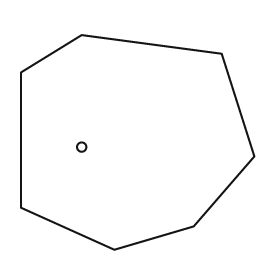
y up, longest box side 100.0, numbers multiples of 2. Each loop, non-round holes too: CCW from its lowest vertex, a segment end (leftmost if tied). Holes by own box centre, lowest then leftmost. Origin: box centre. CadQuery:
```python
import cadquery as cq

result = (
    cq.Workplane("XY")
    .moveTo(-10.0, -46.0)
    .lineTo(24.0, -36.0)
    .lineTo(50.0, -6.0)
    .lineTo(36.0, 38.0)
    .lineTo(-24.0, 46.0)
    .lineTo(-50.0, 30.0)
    .lineTo(-50.0, -28.0)
    .close()
    .moveTo(-24.0, -2.0)
    .circle(2.0)
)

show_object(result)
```